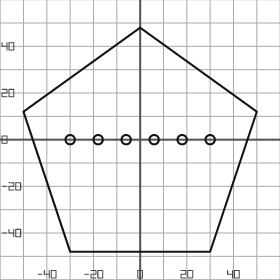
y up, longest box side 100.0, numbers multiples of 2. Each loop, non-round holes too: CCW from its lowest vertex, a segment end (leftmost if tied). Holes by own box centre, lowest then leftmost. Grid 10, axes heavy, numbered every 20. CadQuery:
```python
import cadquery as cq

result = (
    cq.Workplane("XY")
    .moveTo(-30.0, -48.0)
    .lineTo(30.0, -48.0)
    .lineTo(50.0, 12.0)
    .lineTo(0.0, 48.0)
    .lineTo(-50.0, 12.0)
    .close()
    .moveTo(-30.0, 0.0)
    .circle(2.0)
    .moveTo(-18.0, 0.0)
    .circle(2.0)
    .moveTo(-6.0, 0.0)
    .circle(2.0)
    .moveTo(6.0, 0.0)
    .circle(2.0)
    .moveTo(18.0, 0.0)
    .circle(2.0)
    .moveTo(30.0, 0.0)
    .circle(2.0)
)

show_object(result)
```